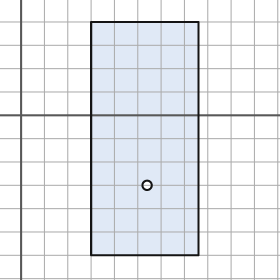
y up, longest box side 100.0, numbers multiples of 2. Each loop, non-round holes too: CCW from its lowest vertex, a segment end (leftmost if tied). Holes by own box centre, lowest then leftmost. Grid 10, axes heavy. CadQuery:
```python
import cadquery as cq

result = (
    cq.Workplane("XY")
    .moveTo(30.0, -60.0)
    .lineTo(76.0, -60.0)
    .lineTo(76.0, 40.0)
    .lineTo(30.0, 40.0)
    .close()
    .moveTo(54.0, -30.0)
    .circle(2.0)
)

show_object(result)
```